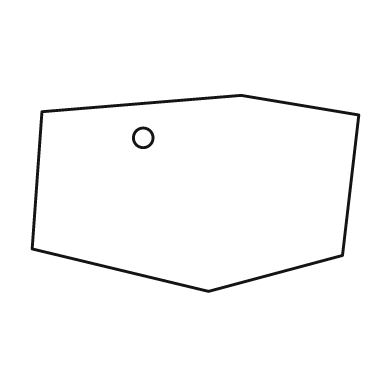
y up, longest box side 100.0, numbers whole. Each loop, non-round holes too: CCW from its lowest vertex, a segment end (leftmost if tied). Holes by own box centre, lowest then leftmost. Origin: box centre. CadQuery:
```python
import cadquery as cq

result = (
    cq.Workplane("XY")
    .moveTo(4.0, -30.0)
    .lineTo(45.0, -19.0)
    .lineTo(50.0, 24.0)
    .lineTo(14.0, 30.0)
    .lineTo(-47.0, 25.0)
    .lineTo(-50.0, -17.0)
    .close()
    .moveTo(-16.0, 17.0)
    .circle(3.0)
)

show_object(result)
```